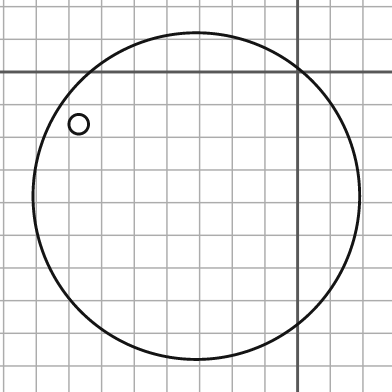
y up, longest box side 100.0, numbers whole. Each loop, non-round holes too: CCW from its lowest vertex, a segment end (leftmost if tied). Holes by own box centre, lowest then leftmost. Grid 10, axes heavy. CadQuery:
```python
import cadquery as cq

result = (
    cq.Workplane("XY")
    .moveTo(-31.0, -38.0)
    .circle(50.0)
    .moveTo(-67.0, -16.0)
    .circle(3.0)
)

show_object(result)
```